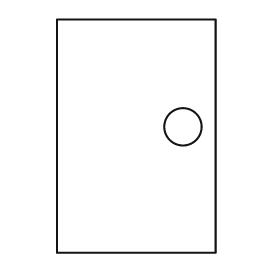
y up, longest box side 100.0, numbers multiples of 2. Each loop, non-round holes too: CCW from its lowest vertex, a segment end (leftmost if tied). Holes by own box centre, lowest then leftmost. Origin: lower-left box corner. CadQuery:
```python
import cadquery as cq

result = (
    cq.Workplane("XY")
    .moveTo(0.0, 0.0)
    .lineTo(68.0, 0.0)
    .lineTo(68.0, 100.0)
    .lineTo(0.0, 100.0)
    .close()
    .moveTo(54.0, 54.0)
    .circle(8.0)
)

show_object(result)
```